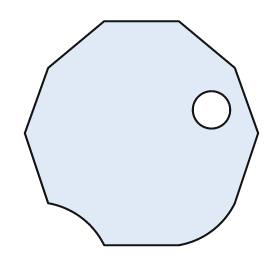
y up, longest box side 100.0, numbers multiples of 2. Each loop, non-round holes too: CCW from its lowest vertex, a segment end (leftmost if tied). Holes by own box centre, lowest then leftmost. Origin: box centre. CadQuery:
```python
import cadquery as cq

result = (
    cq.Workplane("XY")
    .moveTo(-16.0, -48.0)
    .lineTo(16.0, -48.0)
    .threePointArc((30.0, -42.0), (40.0, -30.0))
    .lineTo(50.0, 0.0)
    .lineTo(40.0, 28.0)
    .lineTo(16.0, 48.0)
    .lineTo(-16.0, 48.0)
    .lineTo(-40.0, 28.0)
    .lineTo(-50.0, 0.0)
    .lineTo(-40.0, -30.0)
    .threePointArc((-26.0, -36.0), (-16.0, -48.0))
    .close()
    .moveTo(30.0, 10.0)
    .circle(8.0)
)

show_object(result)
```